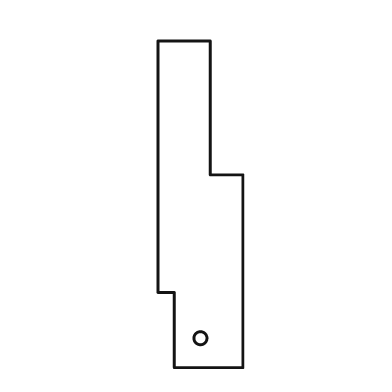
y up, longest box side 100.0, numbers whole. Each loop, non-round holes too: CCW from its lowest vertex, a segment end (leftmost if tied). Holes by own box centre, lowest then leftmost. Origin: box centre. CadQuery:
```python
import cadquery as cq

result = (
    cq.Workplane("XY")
    .moveTo(-8.0, -50.0)
    .lineTo(13.0, -50.0)
    .lineTo(13.0, 9.0)
    .lineTo(3.0, 9.0)
    .lineTo(3.0, 50.0)
    .lineTo(-13.0, 50.0)
    .lineTo(-13.0, -27.0)
    .lineTo(-8.0, -27.0)
    .close()
    .moveTo(0.0, -41.0)
    .circle(2.0)
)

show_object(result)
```